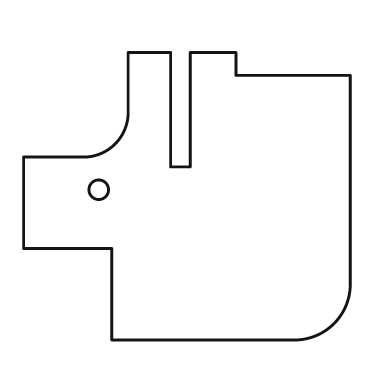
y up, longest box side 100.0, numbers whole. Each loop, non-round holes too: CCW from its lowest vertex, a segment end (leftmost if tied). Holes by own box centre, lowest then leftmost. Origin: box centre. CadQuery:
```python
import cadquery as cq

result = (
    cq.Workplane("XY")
    .moveTo(-23.0, -44.0)
    .lineTo(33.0, -44.0)
    .threePointArc((45.0, -39.0), (50.0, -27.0))
    .lineTo(50.0, 37.0)
    .lineTo(15.0, 37.0)
    .lineTo(15.0, 44.0)
    .lineTo(1.0, 44.0)
    .lineTo(1.0, 9.0)
    .lineTo(-5.0, 9.0)
    .lineTo(-5.0, 44.0)
    .lineTo(-18.0, 44.0)
    .lineTo(-18.0, 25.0)
    .threePointArc((-22.0, 16.0), (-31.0, 12.0))
    .lineTo(-50.0, 12.0)
    .lineTo(-50.0, -16.0)
    .lineTo(-23.0, -16.0)
    .close()
    .moveTo(-27.0, 2.0)
    .circle(3.0)
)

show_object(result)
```